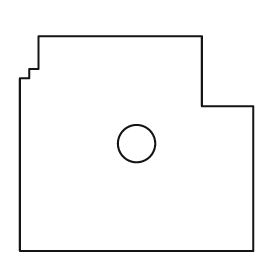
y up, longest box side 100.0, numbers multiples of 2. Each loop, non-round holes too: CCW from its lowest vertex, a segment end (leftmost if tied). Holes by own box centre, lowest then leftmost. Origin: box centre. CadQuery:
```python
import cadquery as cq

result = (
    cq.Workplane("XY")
    .moveTo(-50.0, -46.0)
    .lineTo(50.0, -46.0)
    .lineTo(50.0, 16.0)
    .lineTo(28.0, 16.0)
    .lineTo(28.0, 46.0)
    .lineTo(-42.0, 46.0)
    .lineTo(-42.0, 32.0)
    .lineTo(-46.0, 32.0)
    .lineTo(-46.0, 28.0)
    .lineTo(-50.0, 28.0)
    .close()
    .moveTo(0.0, 0.0)
    .circle(8.0)
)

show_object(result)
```